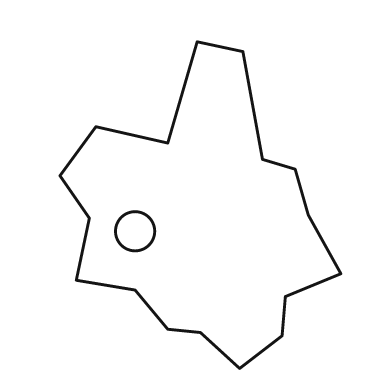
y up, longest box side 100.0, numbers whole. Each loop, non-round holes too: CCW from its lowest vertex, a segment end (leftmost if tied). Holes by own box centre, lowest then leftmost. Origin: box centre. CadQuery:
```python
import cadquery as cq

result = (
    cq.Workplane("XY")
    .moveTo(12.0, -50.0)
    .lineTo(25.0, -40.0)
    .lineTo(26.0, -28.0)
    .lineTo(43.0, -21.0)
    .lineTo(33.0, -3.0)
    .lineTo(29.0, 11.0)
    .lineTo(19.0, 14.0)
    .lineTo(13.0, 47.0)
    .lineTo(-1.0, 50.0)
    .lineTo(-10.0, 19.0)
    .lineTo(-32.0, 24.0)
    .lineTo(-43.0, 9.0)
    .lineTo(-34.0, -4.0)
    .lineTo(-38.0, -23.0)
    .lineTo(-20.0, -26.0)
    .lineTo(-10.0, -38.0)
    .lineTo(0.0, -39.0)
    .close()
    .moveTo(-20.0, -8.0)
    .circle(6.0)
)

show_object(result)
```